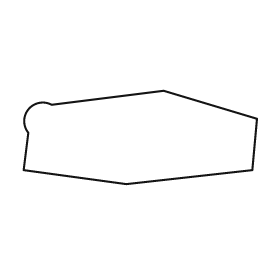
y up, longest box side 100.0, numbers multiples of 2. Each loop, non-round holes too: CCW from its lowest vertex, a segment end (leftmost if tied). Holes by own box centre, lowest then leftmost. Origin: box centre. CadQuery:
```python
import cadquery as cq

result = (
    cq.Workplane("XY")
    .moveTo(-6.0, -20.0)
    .lineTo(48.0, -14.0)
    .lineTo(50.0, 8.0)
    .lineTo(10.0, 20.0)
    .lineTo(-38.0, 14.0)
    .threePointArc((-48.0, 12.0), (-48.0, 2.0))
    .lineTo(-50.0, -14.0)
    .close()
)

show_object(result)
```